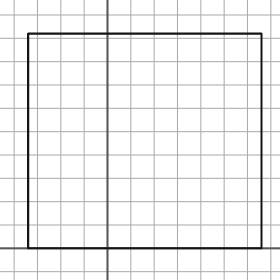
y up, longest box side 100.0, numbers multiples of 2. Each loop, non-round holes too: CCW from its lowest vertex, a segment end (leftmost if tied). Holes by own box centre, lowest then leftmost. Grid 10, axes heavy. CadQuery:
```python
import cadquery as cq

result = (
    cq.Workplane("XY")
    .moveTo(-34.0, 0.0)
    .lineTo(66.0, 0.0)
    .lineTo(66.0, 92.0)
    .lineTo(-34.0, 92.0)
    .close()
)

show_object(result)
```